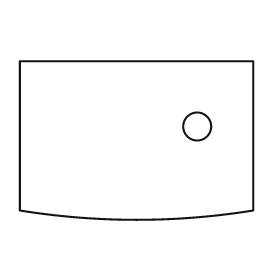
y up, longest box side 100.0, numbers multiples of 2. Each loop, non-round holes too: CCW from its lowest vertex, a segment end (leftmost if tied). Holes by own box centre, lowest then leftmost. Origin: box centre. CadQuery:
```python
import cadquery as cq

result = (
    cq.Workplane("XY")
    .moveTo(-50.0, -30.0)
    .threePointArc((0.0, -34.0), (50.0, -30.0))
    .lineTo(50.0, 34.0)
    .lineTo(-50.0, 34.0)
    .close()
    .moveTo(26.0, 6.0)
    .circle(6.0)
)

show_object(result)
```